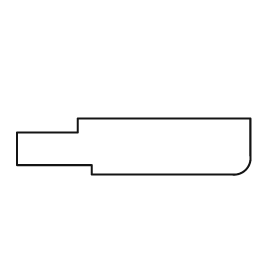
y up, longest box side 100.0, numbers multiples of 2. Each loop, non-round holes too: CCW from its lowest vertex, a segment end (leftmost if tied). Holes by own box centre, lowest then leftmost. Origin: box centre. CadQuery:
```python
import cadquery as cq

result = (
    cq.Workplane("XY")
    .moveTo(-18.0, -12.0)
    .lineTo(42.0, -12.0)
    .threePointArc((48.0, -10.0), (50.0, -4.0))
    .lineTo(50.0, 12.0)
    .lineTo(-24.0, 12.0)
    .lineTo(-24.0, 6.0)
    .lineTo(-50.0, 6.0)
    .lineTo(-50.0, -8.0)
    .lineTo(-18.0, -8.0)
    .close()
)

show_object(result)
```